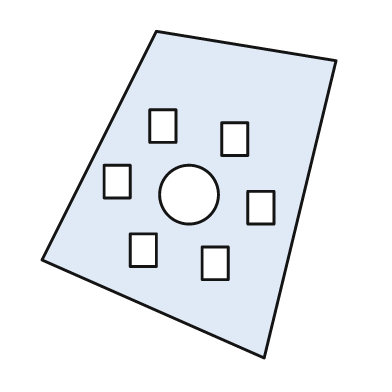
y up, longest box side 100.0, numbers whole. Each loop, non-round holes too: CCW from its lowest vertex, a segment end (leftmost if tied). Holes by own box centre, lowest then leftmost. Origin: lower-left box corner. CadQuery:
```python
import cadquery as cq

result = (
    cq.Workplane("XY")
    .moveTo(68.0, 0.0)
    .lineTo(90.0, 91.0)
    .lineTo(35.0, 100.0)
    .lineTo(0.0, 30.0)
    .close()
    .moveTo(49.0, 24.0)
    .lineTo(57.0, 24.0)
    .lineTo(57.0, 34.0)
    .lineTo(49.0, 34.0)
    .close()
    .moveTo(27.0, 28.0)
    .lineTo(35.0, 28.0)
    .lineTo(35.0, 38.0)
    .lineTo(27.0, 38.0)
    .close()
    .moveTo(63.0, 41.0)
    .lineTo(71.0, 41.0)
    .lineTo(71.0, 51.0)
    .lineTo(63.0, 51.0)
    .close()
    .moveTo(45.0, 50.0)
    .circle(9.0)
    .moveTo(19.0, 49.0)
    .lineTo(27.0, 49.0)
    .lineTo(27.0, 59.0)
    .lineTo(19.0, 59.0)
    .close()
    .moveTo(55.0, 62.0)
    .lineTo(63.0, 62.0)
    .lineTo(63.0, 72.0)
    .lineTo(55.0, 72.0)
    .close()
    .moveTo(33.0, 66.0)
    .lineTo(41.0, 66.0)
    .lineTo(41.0, 76.0)
    .lineTo(33.0, 76.0)
    .close()
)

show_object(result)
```